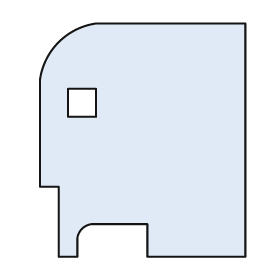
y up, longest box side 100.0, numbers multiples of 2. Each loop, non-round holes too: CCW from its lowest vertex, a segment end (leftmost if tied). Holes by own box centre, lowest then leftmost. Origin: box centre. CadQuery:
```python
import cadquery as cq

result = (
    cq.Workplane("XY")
    .moveTo(-36.0, -50.0)
    .lineTo(-28.0, -50.0)
    .lineTo(-28.0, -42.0)
    .threePointArc((-26.0, -38.0), (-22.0, -36.0))
    .lineTo(2.0, -36.0)
    .lineTo(2.0, -50.0)
    .lineTo(44.0, -50.0)
    .lineTo(44.0, 50.0)
    .lineTo(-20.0, 50.0)
    .threePointArc((-36.0, 42.0), (-44.0, 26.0))
    .lineTo(-44.0, -20.0)
    .lineTo(-36.0, -20.0)
    .close()
    .moveTo(-32.0, 10.0)
    .lineTo(-20.0, 10.0)
    .lineTo(-20.0, 22.0)
    .lineTo(-32.0, 22.0)
    .close()
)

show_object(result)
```